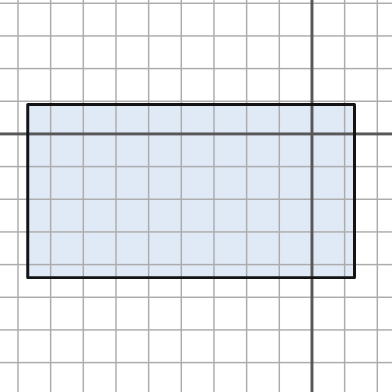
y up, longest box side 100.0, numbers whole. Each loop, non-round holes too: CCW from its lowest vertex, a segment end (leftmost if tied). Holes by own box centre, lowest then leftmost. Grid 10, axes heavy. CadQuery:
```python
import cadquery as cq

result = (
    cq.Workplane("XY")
    .moveTo(-87.0, -44.0)
    .lineTo(13.0, -44.0)
    .lineTo(13.0, 9.0)
    .lineTo(-87.0, 9.0)
    .close()
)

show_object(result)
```